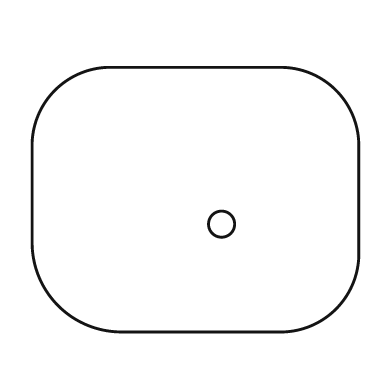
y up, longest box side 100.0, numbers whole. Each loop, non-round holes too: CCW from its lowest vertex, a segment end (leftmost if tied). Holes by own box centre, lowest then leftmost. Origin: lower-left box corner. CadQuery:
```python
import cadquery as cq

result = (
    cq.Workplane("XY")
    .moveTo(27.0, 0.0)
    .lineTo(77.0, 0.0)
    .threePointArc((93.0, 7.0), (100.0, 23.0))
    .lineTo(100.0, 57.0)
    .threePointArc((93.0, 74.0), (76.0, 81.0))
    .lineTo(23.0, 81.0)
    .threePointArc((7.0, 74.0), (0.0, 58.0))
    .lineTo(0.0, 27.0)
    .threePointArc((8.0, 8.0), (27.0, 0.0))
    .close()
    .moveTo(58.0, 33.0)
    .circle(4.0)
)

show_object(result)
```